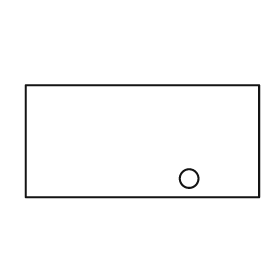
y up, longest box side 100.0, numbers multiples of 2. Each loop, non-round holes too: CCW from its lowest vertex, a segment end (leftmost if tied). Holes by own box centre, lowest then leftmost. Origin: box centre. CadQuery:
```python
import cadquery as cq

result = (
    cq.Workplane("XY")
    .moveTo(-50.0, -24.0)
    .lineTo(50.0, -24.0)
    .lineTo(50.0, 24.0)
    .lineTo(-50.0, 24.0)
    .close()
    .moveTo(20.0, -16.0)
    .circle(4.0)
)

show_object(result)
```